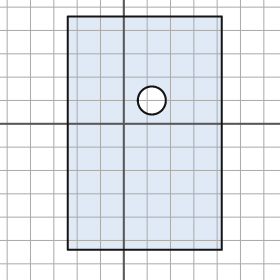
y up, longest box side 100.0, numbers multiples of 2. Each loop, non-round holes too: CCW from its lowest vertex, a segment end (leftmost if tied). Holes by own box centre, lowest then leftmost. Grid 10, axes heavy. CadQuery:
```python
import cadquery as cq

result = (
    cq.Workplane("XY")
    .moveTo(-24.0, -54.0)
    .lineTo(42.0, -54.0)
    .lineTo(42.0, 46.0)
    .lineTo(-24.0, 46.0)
    .close()
    .moveTo(12.0, 10.0)
    .circle(6.0)
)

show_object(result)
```